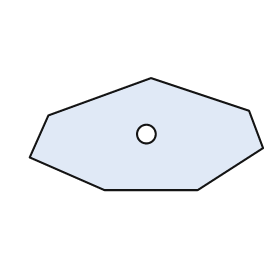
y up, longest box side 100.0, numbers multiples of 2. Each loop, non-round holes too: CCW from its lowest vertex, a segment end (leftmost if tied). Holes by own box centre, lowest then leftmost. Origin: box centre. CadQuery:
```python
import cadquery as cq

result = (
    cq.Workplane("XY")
    .moveTo(-18.0, -24.0)
    .lineTo(22.0, -24.0)
    .lineTo(50.0, -6.0)
    .lineTo(44.0, 10.0)
    .lineTo(2.0, 24.0)
    .lineTo(-42.0, 8.0)
    .lineTo(-50.0, -10.0)
    .close()
    .moveTo(0.0, 0.0)
    .circle(4.0)
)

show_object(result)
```